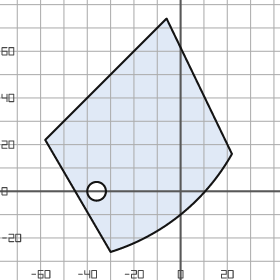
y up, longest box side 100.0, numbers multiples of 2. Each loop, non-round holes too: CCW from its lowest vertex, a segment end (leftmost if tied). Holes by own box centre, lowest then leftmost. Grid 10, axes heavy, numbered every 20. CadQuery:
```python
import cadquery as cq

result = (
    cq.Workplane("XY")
    .moveTo(-30.0, -26.0)
    .threePointArc((0.0, -10.0), (22.0, 16.0))
    .lineTo(-6.0, 74.0)
    .lineTo(-58.0, 22.0)
    .close()
    .moveTo(-36.0, 0.0)
    .circle(4.0)
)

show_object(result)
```